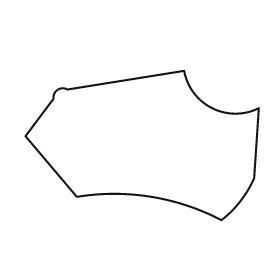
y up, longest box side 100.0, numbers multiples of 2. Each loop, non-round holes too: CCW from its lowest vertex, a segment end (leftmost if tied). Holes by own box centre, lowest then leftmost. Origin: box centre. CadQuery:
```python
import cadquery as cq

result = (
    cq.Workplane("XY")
    .moveTo(34.0, -32.0)
    .threePointArc((42.0, -24.0), (48.0, -14.0))
    .lineTo(50.0, 16.0)
    .threePointArc((30.0, 16.0), (18.0, 32.0))
    .lineTo(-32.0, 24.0)
    .threePointArc((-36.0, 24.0), (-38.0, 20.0))
    .lineTo(-50.0, 4.0)
    .lineTo(-28.0, -22.0)
    .threePointArc((4.0, -22.0), (34.0, -32.0))
    .close()
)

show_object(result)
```